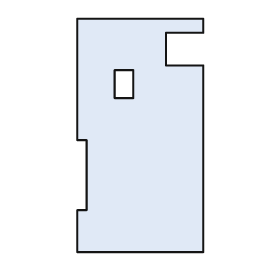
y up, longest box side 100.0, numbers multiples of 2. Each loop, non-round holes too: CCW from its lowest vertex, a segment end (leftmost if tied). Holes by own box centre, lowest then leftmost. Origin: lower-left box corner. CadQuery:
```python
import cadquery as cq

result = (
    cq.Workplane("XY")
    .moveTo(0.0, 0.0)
    .lineTo(54.0, 0.0)
    .lineTo(54.0, 80.0)
    .lineTo(38.0, 80.0)
    .lineTo(38.0, 94.0)
    .lineTo(54.0, 94.0)
    .lineTo(54.0, 100.0)
    .lineTo(0.0, 100.0)
    .lineTo(0.0, 48.0)
    .lineTo(4.0, 48.0)
    .lineTo(4.0, 18.0)
    .lineTo(0.0, 18.0)
    .close()
    .moveTo(16.0, 66.0)
    .lineTo(24.0, 66.0)
    .lineTo(24.0, 78.0)
    .lineTo(16.0, 78.0)
    .close()
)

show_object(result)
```